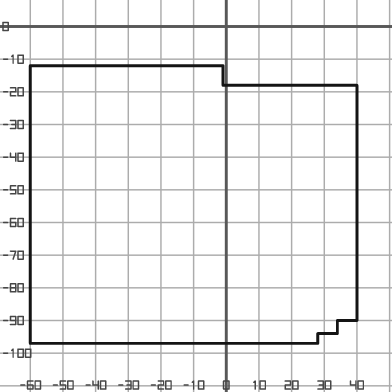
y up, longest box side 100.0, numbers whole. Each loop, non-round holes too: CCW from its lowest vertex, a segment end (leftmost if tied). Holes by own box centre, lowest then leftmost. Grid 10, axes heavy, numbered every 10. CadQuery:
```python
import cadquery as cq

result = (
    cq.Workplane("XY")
    .moveTo(-60.0, -97.0)
    .lineTo(28.0, -97.0)
    .lineTo(28.0, -94.0)
    .lineTo(34.0, -94.0)
    .lineTo(34.0, -90.0)
    .lineTo(40.0, -90.0)
    .lineTo(40.0, -18.0)
    .lineTo(-1.0, -18.0)
    .lineTo(-1.0, -12.0)
    .lineTo(-60.0, -12.0)
    .close()
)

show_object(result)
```